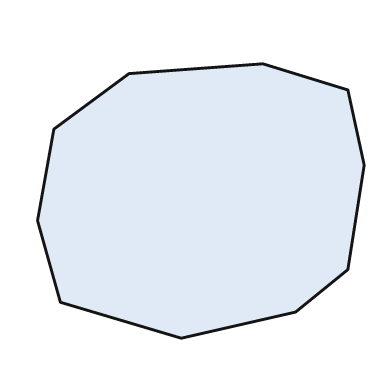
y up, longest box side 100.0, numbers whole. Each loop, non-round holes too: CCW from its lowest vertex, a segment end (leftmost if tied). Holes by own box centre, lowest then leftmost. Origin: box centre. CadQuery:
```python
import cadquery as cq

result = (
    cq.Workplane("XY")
    .moveTo(-6.0, -42.0)
    .lineTo(29.0, -34.0)
    .lineTo(45.0, -21.0)
    .lineTo(50.0, 11.0)
    .lineTo(45.0, 34.0)
    .lineTo(19.0, 42.0)
    .lineTo(-22.0, 39.0)
    .lineTo(-45.0, 22.0)
    .lineTo(-50.0, -6.0)
    .lineTo(-43.0, -31.0)
    .close()
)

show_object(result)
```